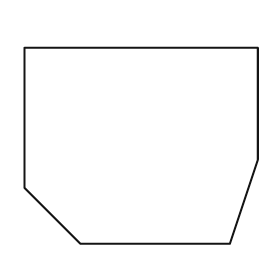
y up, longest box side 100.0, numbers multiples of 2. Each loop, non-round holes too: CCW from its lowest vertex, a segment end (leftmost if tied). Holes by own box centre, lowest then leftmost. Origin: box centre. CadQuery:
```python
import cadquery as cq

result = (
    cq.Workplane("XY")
    .moveTo(-26.0, -42.0)
    .lineTo(38.0, -42.0)
    .lineTo(50.0, -6.0)
    .lineTo(50.0, 42.0)
    .lineTo(-50.0, 42.0)
    .lineTo(-50.0, -18.0)
    .close()
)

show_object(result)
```